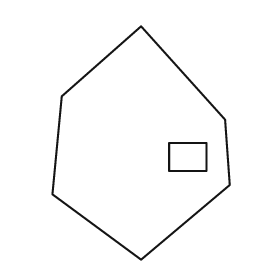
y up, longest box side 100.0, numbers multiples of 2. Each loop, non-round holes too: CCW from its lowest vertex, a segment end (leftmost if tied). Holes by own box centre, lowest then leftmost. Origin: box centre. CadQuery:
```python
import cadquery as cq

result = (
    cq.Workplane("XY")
    .moveTo(0.0, -50.0)
    .lineTo(38.0, -18.0)
    .lineTo(36.0, 10.0)
    .lineTo(0.0, 50.0)
    .lineTo(-34.0, 20.0)
    .lineTo(-38.0, -22.0)
    .close()
    .moveTo(12.0, -12.0)
    .lineTo(28.0, -12.0)
    .lineTo(28.0, 0.0)
    .lineTo(12.0, 0.0)
    .close()
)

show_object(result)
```